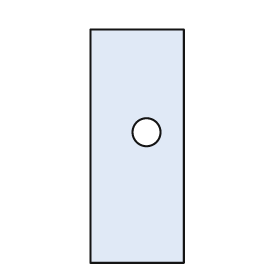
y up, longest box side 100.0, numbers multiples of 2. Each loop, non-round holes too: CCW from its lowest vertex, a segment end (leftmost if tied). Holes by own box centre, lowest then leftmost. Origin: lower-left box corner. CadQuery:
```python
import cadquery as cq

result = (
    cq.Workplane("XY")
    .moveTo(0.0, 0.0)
    .lineTo(40.0, 0.0)
    .lineTo(40.0, 100.0)
    .lineTo(0.0, 100.0)
    .close()
    .moveTo(24.0, 56.0)
    .circle(6.0)
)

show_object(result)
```